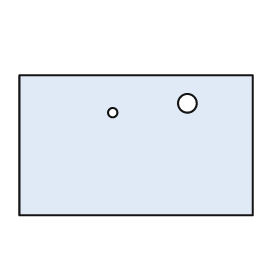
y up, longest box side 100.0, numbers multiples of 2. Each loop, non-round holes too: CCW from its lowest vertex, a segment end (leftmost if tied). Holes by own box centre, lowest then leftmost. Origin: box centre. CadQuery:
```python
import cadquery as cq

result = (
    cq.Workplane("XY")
    .moveTo(-50.0, -30.0)
    .lineTo(50.0, -30.0)
    .lineTo(50.0, 30.0)
    .lineTo(-50.0, 30.0)
    .close()
    .moveTo(-10.0, 14.0)
    .circle(2.0)
    .moveTo(22.0, 18.0)
    .circle(4.0)
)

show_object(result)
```